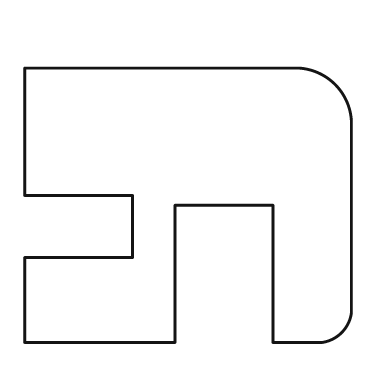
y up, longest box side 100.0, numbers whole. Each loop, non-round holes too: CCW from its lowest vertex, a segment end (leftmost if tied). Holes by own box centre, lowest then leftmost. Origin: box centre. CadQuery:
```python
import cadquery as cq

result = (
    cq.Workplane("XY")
    .moveTo(-50.0, -42.0)
    .lineTo(-4.0, -42.0)
    .lineTo(-4.0, 0.0)
    .lineTo(26.0, 0.0)
    .lineTo(26.0, -42.0)
    .lineTo(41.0, -42.0)
    .threePointArc((47.0, -39.0), (50.0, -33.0))
    .lineTo(50.0, 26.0)
    .threePointArc((45.0, 37.0), (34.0, 42.0))
    .lineTo(-50.0, 42.0)
    .lineTo(-50.0, 3.0)
    .lineTo(-17.0, 3.0)
    .lineTo(-17.0, -16.0)
    .lineTo(-50.0, -16.0)
    .close()
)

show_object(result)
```